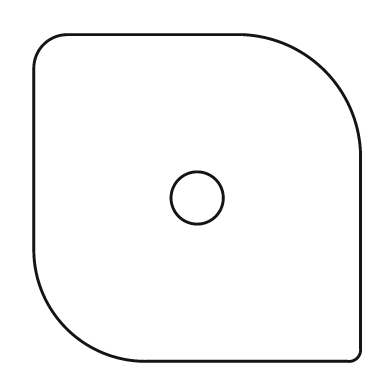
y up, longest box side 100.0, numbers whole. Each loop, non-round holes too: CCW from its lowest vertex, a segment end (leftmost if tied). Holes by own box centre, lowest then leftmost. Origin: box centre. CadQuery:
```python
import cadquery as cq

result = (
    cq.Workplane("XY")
    .moveTo(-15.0, -50.0)
    .lineTo(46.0, -50.0)
    .threePointArc((49.0, -49.0), (50.0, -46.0))
    .lineTo(50.0, 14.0)
    .threePointArc((39.0, 39.0), (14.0, 50.0))
    .lineTo(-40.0, 50.0)
    .threePointArc((-47.0, 47.0), (-50.0, 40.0))
    .lineTo(-50.0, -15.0)
    .threePointArc((-40.0, -40.0), (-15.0, -50.0))
    .close()
    .moveTo(0.0, 0.0)
    .circle(8.0)
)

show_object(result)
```